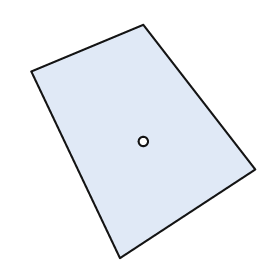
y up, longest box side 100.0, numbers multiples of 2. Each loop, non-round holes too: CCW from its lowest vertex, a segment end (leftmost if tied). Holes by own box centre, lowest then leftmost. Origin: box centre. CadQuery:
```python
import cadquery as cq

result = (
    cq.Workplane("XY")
    .moveTo(-10.0, -50.0)
    .lineTo(48.0, -12.0)
    .lineTo(0.0, 50.0)
    .lineTo(-48.0, 30.0)
    .close()
    .moveTo(0.0, 0.0)
    .circle(2.0)
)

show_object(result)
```